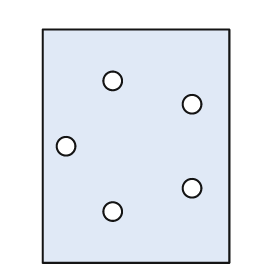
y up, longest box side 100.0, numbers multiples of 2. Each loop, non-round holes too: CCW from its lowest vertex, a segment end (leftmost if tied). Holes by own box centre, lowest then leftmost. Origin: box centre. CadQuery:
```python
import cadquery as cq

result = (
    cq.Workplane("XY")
    .moveTo(-40.0, -50.0)
    .lineTo(40.0, -50.0)
    .lineTo(40.0, 50.0)
    .lineTo(-40.0, 50.0)
    .close()
    .moveTo(-10.0, -28.0)
    .circle(4.0)
    .moveTo(24.0, -18.0)
    .circle(4.0)
    .moveTo(-30.0, 0.0)
    .circle(4.0)
    .moveTo(24.0, 18.0)
    .circle(4.0)
    .moveTo(-10.0, 28.0)
    .circle(4.0)
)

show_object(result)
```